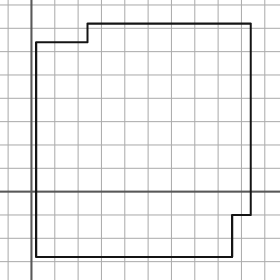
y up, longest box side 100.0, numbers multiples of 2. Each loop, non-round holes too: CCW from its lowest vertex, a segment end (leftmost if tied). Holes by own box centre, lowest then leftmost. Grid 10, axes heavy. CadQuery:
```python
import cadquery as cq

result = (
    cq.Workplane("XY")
    .moveTo(2.0, -28.0)
    .lineTo(86.0, -28.0)
    .lineTo(86.0, -10.0)
    .lineTo(94.0, -10.0)
    .lineTo(94.0, 72.0)
    .lineTo(24.0, 72.0)
    .lineTo(24.0, 64.0)
    .lineTo(2.0, 64.0)
    .close()
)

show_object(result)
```